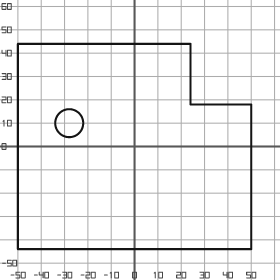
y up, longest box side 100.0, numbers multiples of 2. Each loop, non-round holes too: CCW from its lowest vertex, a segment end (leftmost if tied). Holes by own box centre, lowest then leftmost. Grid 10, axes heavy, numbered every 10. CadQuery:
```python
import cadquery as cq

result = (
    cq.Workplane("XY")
    .moveTo(-50.0, -44.0)
    .lineTo(50.0, -44.0)
    .lineTo(50.0, 18.0)
    .lineTo(24.0, 18.0)
    .lineTo(24.0, 44.0)
    .lineTo(-50.0, 44.0)
    .close()
    .moveTo(-28.0, 10.0)
    .circle(6.0)
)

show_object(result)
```